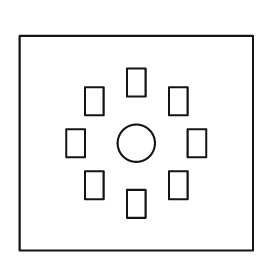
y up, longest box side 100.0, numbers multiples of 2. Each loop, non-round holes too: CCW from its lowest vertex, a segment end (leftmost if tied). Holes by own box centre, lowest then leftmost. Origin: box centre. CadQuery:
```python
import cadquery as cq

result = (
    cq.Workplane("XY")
    .moveTo(-50.0, -46.0)
    .lineTo(50.0, -46.0)
    .lineTo(50.0, 46.0)
    .lineTo(-50.0, 46.0)
    .close()
    .moveTo(-4.0, -32.0)
    .lineTo(4.0, -32.0)
    .lineTo(4.0, -20.0)
    .lineTo(-4.0, -20.0)
    .close()
    .moveTo(-22.0, -24.0)
    .lineTo(-14.0, -24.0)
    .lineTo(-14.0, -12.0)
    .lineTo(-22.0, -12.0)
    .close()
    .moveTo(14.0, -24.0)
    .lineTo(22.0, -24.0)
    .lineTo(22.0, -12.0)
    .lineTo(14.0, -12.0)
    .close()
    .moveTo(-30.0, -6.0)
    .lineTo(-22.0, -6.0)
    .lineTo(-22.0, 6.0)
    .lineTo(-30.0, 6.0)
    .close()
    .moveTo(0.0, 0.0)
    .circle(8.0)
    .moveTo(22.0, -6.0)
    .lineTo(30.0, -6.0)
    .lineTo(30.0, 6.0)
    .lineTo(22.0, 6.0)
    .close()
    .moveTo(-22.0, 12.0)
    .lineTo(-14.0, 12.0)
    .lineTo(-14.0, 24.0)
    .lineTo(-22.0, 24.0)
    .close()
    .moveTo(14.0, 12.0)
    .lineTo(22.0, 12.0)
    .lineTo(22.0, 24.0)
    .lineTo(14.0, 24.0)
    .close()
    .moveTo(-4.0, 20.0)
    .lineTo(4.0, 20.0)
    .lineTo(4.0, 32.0)
    .lineTo(-4.0, 32.0)
    .close()
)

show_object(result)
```